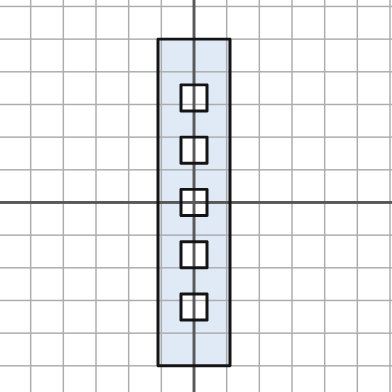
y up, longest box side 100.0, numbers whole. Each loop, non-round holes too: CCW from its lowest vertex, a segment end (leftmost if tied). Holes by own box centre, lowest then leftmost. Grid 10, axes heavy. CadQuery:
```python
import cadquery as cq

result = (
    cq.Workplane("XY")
    .moveTo(-11.0, -50.0)
    .lineTo(11.0, -50.0)
    .lineTo(11.0, 50.0)
    .lineTo(-11.0, 50.0)
    .close()
    .moveTo(-4.0, -36.0)
    .lineTo(4.0, -36.0)
    .lineTo(4.0, -28.0)
    .lineTo(-4.0, -28.0)
    .close()
    .moveTo(-4.0, -20.0)
    .lineTo(4.0, -20.0)
    .lineTo(4.0, -12.0)
    .lineTo(-4.0, -12.0)
    .close()
    .moveTo(-4.0, -4.0)
    .lineTo(4.0, -4.0)
    .lineTo(4.0, 4.0)
    .lineTo(-4.0, 4.0)
    .close()
    .moveTo(-4.0, 12.0)
    .lineTo(4.0, 12.0)
    .lineTo(4.0, 20.0)
    .lineTo(-4.0, 20.0)
    .close()
    .moveTo(-4.0, 28.0)
    .lineTo(4.0, 28.0)
    .lineTo(4.0, 36.0)
    .lineTo(-4.0, 36.0)
    .close()
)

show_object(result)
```